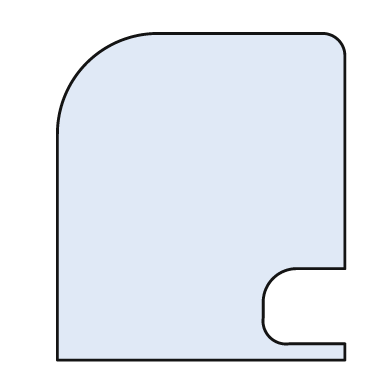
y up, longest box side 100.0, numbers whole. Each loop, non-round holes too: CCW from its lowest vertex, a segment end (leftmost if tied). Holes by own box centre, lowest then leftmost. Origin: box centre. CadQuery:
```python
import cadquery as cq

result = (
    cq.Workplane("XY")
    .moveTo(-44.0, -50.0)
    .lineTo(44.0, -50.0)
    .lineTo(44.0, -45.0)
    .lineTo(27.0, -45.0)
    .threePointArc((21.0, -43.0), (19.0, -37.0))
    .lineTo(19.0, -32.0)
    .threePointArc((22.0, -25.0), (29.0, -22.0))
    .lineTo(44.0, -22.0)
    .lineTo(44.0, 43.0)
    .threePointArc((42.0, 48.0), (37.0, 50.0))
    .lineTo(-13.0, 50.0)
    .threePointArc((-35.0, 41.0), (-44.0, 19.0))
    .close()
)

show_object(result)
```